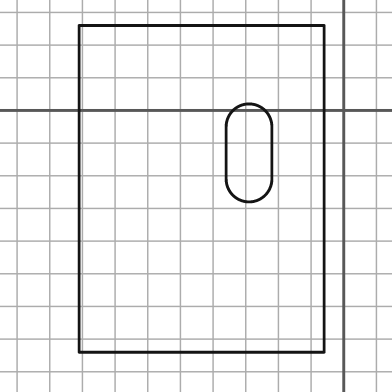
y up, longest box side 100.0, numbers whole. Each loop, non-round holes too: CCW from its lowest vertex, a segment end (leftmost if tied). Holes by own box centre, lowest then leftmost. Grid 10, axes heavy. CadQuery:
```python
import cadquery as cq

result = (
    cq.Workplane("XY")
    .moveTo(-81.0, -74.0)
    .lineTo(-6.0, -74.0)
    .lineTo(-6.0, 26.0)
    .lineTo(-81.0, 26.0)
    .close()
    .moveTo(-36.0, -21.0)
    .threePointArc((-29.0, -28.0), (-22.0, -21.0))
    .lineTo(-22.0, -5.0)
    .threePointArc((-29.0, 2.0), (-36.0, -5.0))
    .close()
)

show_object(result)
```